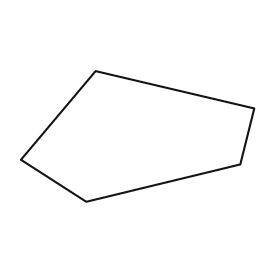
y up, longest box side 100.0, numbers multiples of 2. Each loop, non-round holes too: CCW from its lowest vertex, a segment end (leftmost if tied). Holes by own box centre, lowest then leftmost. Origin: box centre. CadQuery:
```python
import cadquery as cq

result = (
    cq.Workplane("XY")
    .moveTo(-22.0, -28.0)
    .lineTo(44.0, -12.0)
    .lineTo(50.0, 12.0)
    .lineTo(-18.0, 28.0)
    .lineTo(-50.0, -10.0)
    .close()
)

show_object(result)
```